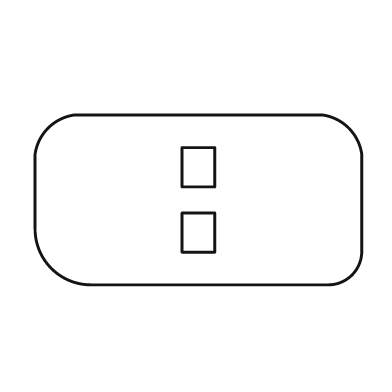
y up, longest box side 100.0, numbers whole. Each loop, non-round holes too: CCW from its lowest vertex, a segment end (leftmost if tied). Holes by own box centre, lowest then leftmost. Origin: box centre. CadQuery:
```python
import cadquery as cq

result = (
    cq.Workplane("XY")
    .moveTo(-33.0, -26.0)
    .lineTo(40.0, -26.0)
    .threePointArc((47.0, -23.0), (50.0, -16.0))
    .lineTo(50.0, 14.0)
    .threePointArc((46.0, 22.0), (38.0, 26.0))
    .lineTo(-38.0, 26.0)
    .threePointArc((-46.0, 22.0), (-50.0, 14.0))
    .lineTo(-50.0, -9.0)
    .threePointArc((-45.0, -21.0), (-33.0, -26.0))
    .close()
    .moveTo(-5.0, -16.0)
    .lineTo(5.0, -16.0)
    .lineTo(5.0, -4.0)
    .lineTo(-5.0, -4.0)
    .close()
    .moveTo(-5.0, 4.0)
    .lineTo(5.0, 4.0)
    .lineTo(5.0, 16.0)
    .lineTo(-5.0, 16.0)
    .close()
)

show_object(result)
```